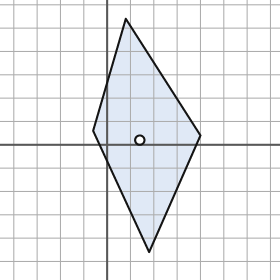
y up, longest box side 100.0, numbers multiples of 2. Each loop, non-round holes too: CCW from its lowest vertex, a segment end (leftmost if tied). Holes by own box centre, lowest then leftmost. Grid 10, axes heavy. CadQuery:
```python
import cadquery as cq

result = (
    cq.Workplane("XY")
    .moveTo(18.0, -46.0)
    .lineTo(40.0, 4.0)
    .lineTo(8.0, 54.0)
    .lineTo(-6.0, 6.0)
    .close()
    .moveTo(14.0, 2.0)
    .circle(2.0)
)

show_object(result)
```